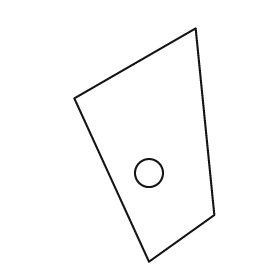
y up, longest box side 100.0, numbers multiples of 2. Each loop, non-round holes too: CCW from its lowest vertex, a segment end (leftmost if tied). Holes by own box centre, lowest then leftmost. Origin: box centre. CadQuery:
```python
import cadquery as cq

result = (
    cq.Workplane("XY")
    .moveTo(2.0, -50.0)
    .lineTo(30.0, -30.0)
    .lineTo(22.0, 50.0)
    .lineTo(-30.0, 20.0)
    .close()
    .moveTo(2.0, -12.0)
    .circle(6.0)
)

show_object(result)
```